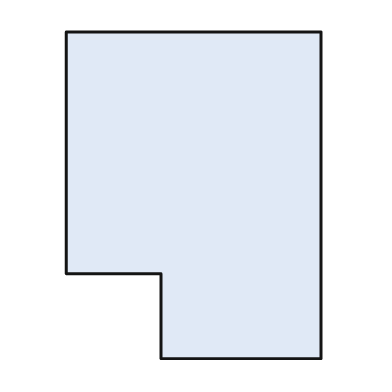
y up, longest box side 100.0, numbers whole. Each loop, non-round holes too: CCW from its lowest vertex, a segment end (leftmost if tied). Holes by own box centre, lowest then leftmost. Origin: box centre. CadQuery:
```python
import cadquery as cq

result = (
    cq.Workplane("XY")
    .moveTo(-10.0, -50.0)
    .lineTo(39.0, -50.0)
    .lineTo(39.0, 50.0)
    .lineTo(-39.0, 50.0)
    .lineTo(-39.0, -24.0)
    .lineTo(-10.0, -24.0)
    .close()
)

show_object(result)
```